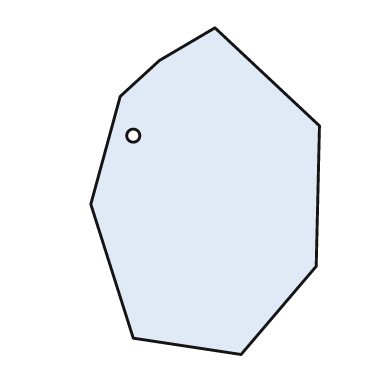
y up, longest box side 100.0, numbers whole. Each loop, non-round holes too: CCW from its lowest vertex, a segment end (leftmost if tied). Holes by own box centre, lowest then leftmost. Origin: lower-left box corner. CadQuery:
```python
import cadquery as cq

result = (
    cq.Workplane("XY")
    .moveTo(46.0, 0.0)
    .lineTo(69.0, 27.0)
    .lineTo(70.0, 70.0)
    .lineTo(38.0, 100.0)
    .lineTo(21.0, 90.0)
    .lineTo(9.0, 79.0)
    .lineTo(0.0, 46.0)
    .lineTo(13.0, 5.0)
    .close()
    .moveTo(13.0, 67.0)
    .circle(2.0)
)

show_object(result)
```